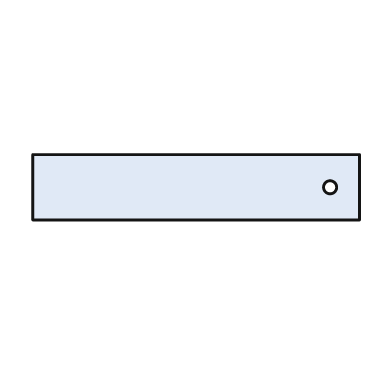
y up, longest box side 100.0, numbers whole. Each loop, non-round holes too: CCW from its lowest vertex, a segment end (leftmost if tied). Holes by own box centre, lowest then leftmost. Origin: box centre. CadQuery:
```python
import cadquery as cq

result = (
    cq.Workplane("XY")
    .moveTo(-50.0, -10.0)
    .lineTo(50.0, -10.0)
    .lineTo(50.0, 10.0)
    .lineTo(-50.0, 10.0)
    .close()
    .moveTo(41.0, 0.0)
    .circle(2.0)
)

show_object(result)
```